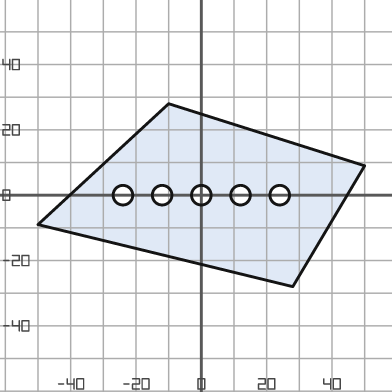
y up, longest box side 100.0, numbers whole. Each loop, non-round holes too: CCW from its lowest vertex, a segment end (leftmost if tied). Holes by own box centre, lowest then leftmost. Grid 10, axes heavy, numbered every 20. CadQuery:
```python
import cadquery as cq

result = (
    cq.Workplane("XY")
    .moveTo(28.0, -28.0)
    .lineTo(50.0, 9.0)
    .lineTo(-10.0, 28.0)
    .lineTo(-50.0, -9.0)
    .close()
    .moveTo(-24.0, 0.0)
    .circle(3.0)
    .moveTo(-12.0, 0.0)
    .circle(3.0)
    .moveTo(0.0, 0.0)
    .circle(3.0)
    .moveTo(12.0, 0.0)
    .circle(3.0)
    .moveTo(24.0, 0.0)
    .circle(3.0)
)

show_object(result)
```